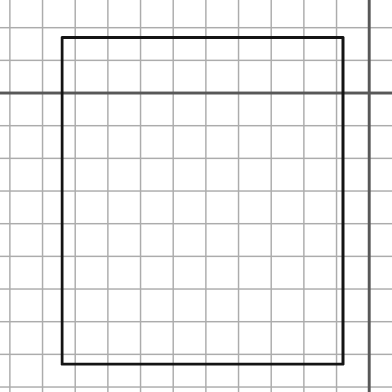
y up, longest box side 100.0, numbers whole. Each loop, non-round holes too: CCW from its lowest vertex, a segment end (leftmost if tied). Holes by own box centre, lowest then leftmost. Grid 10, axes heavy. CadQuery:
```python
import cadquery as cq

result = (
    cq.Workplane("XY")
    .moveTo(-94.0, -83.0)
    .lineTo(-8.0, -83.0)
    .lineTo(-8.0, 17.0)
    .lineTo(-94.0, 17.0)
    .close()
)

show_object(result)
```